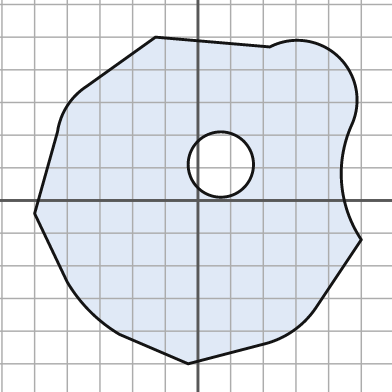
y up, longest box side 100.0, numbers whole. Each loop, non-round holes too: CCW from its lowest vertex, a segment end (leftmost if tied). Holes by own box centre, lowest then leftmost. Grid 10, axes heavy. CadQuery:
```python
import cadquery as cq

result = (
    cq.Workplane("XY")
    .moveTo(-3.0, -50.0)
    .lineTo(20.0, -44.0)
    .threePointArc((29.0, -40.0), (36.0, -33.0))
    .lineTo(50.0, -12.0)
    .threePointArc((44.0, 5.0), (47.0, 23.0))
    .threePointArc((43.0, 44.0), (22.0, 47.0))
    .lineTo(-13.0, 50.0)
    .lineTo(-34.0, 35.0)
    .threePointArc((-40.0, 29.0), (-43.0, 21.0))
    .lineTo(-50.0, -4.0)
    .lineTo(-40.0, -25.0)
    .threePointArc((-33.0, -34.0), (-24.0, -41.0))
    .close()
    .moveTo(7.0, 11.0)
    .circle(10.0)
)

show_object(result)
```